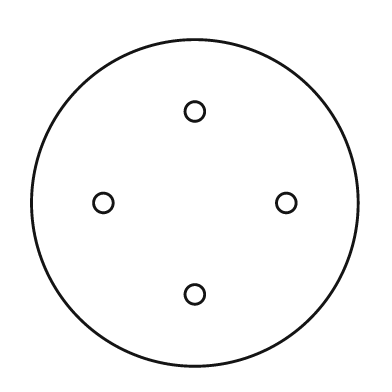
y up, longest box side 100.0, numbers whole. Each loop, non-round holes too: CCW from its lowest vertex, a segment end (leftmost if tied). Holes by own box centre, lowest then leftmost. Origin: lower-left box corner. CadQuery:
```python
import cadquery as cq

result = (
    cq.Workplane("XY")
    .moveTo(50.0, 50.0)
    .circle(50.0)
    .moveTo(50.0, 22.0)
    .circle(3.0)
    .moveTo(22.0, 50.0)
    .circle(3.0)
    .moveTo(78.0, 50.0)
    .circle(3.0)
    .moveTo(50.0, 78.0)
    .circle(3.0)
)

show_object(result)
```